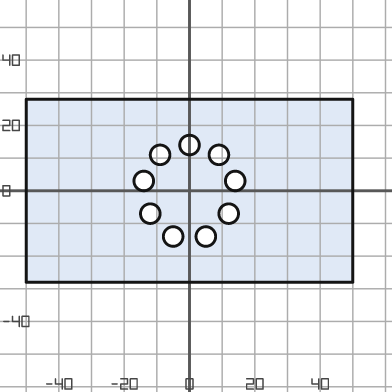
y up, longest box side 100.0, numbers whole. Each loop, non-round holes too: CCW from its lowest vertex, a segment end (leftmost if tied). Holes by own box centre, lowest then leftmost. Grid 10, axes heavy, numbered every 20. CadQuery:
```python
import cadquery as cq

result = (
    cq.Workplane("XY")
    .moveTo(-50.0, -28.0)
    .lineTo(50.0, -28.0)
    .lineTo(50.0, 28.0)
    .lineTo(-50.0, 28.0)
    .close()
    .moveTo(-5.0, -14.0)
    .circle(3.0)
    .moveTo(5.0, -14.0)
    .circle(3.0)
    .moveTo(-12.0, -7.0)
    .circle(3.0)
    .moveTo(12.0, -7.0)
    .circle(3.0)
    .moveTo(-14.0, 3.0)
    .circle(3.0)
    .moveTo(14.0, 3.0)
    .circle(3.0)
    .moveTo(-9.0, 11.0)
    .circle(3.0)
    .moveTo(9.0, 11.0)
    .circle(3.0)
    .moveTo(0.0, 14.0)
    .circle(3.0)
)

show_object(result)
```